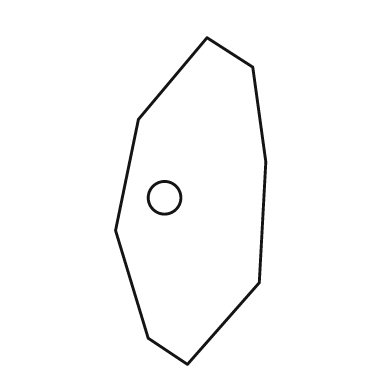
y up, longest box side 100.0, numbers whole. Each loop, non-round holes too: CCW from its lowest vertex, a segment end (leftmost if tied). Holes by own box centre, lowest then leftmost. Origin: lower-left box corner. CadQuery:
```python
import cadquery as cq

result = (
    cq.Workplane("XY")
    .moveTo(22.0, 0.0)
    .lineTo(44.0, 25.0)
    .lineTo(46.0, 62.0)
    .lineTo(42.0, 91.0)
    .lineTo(28.0, 100.0)
    .lineTo(7.0, 75.0)
    .lineTo(0.0, 41.0)
    .lineTo(10.0, 8.0)
    .close()
    .moveTo(15.0, 51.0)
    .circle(5.0)
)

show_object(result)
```